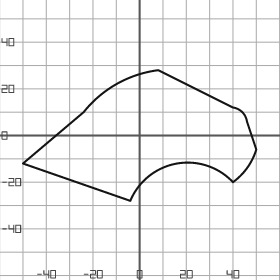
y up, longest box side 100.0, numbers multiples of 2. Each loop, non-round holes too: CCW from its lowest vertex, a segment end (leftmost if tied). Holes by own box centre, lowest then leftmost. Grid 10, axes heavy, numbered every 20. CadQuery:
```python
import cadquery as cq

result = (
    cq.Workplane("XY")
    .moveTo(-4.0, -28.0)
    .threePointArc((16.0, -12.0), (40.0, -20.0))
    .threePointArc((46.0, -14.0), (50.0, -6.0))
    .lineTo(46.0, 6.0)
    .threePointArc((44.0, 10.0), (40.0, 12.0))
    .lineTo(8.0, 28.0)
    .threePointArc((-10.0, 22.0), (-24.0, 10.0))
    .lineTo(-50.0, -12.0)
    .close()
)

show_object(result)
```